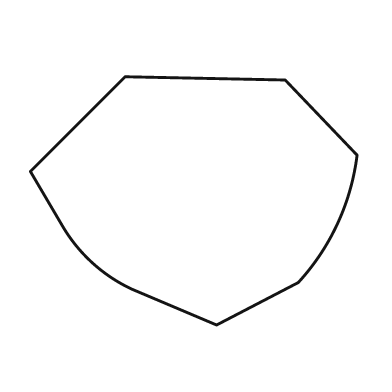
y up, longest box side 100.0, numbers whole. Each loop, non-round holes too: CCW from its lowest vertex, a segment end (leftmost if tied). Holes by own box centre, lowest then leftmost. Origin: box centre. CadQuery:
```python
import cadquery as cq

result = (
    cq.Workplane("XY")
    .moveTo(7.0, -38.0)
    .lineTo(32.0, -25.0)
    .threePointArc((44.0, -7.0), (50.0, 14.0))
    .lineTo(28.0, 37.0)
    .lineTo(-21.0, 38.0)
    .lineTo(-50.0, 9.0)
    .lineTo(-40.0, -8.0)
    .threePointArc((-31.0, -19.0), (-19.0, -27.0))
    .close()
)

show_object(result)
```